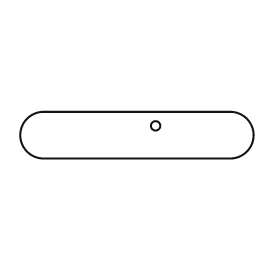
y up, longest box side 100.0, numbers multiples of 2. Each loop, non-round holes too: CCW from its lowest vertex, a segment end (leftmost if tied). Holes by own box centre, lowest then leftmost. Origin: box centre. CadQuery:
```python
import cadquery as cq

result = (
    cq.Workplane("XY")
    .moveTo(-40.0, -10.0)
    .lineTo(40.0, -10.0)
    .threePointArc((50.0, 0.0), (40.0, 10.0))
    .lineTo(-40.0, 10.0)
    .threePointArc((-50.0, 0.0), (-40.0, -10.0))
    .close()
    .moveTo(8.0, 4.0)
    .circle(2.0)
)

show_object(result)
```